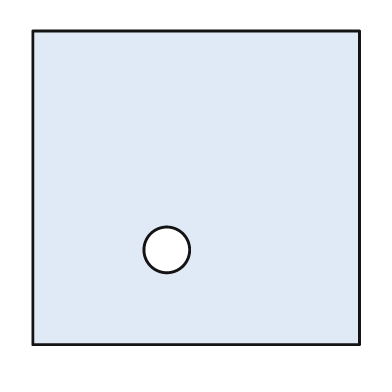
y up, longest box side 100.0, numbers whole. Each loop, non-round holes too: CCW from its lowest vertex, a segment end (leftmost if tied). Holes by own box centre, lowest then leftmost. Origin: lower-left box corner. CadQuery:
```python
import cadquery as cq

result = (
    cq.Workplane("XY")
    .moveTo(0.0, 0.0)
    .lineTo(100.0, 0.0)
    .lineTo(100.0, 96.0)
    .lineTo(0.0, 96.0)
    .close()
    .moveTo(41.0, 29.0)
    .circle(7.0)
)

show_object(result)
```